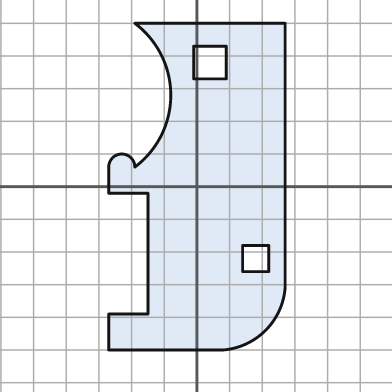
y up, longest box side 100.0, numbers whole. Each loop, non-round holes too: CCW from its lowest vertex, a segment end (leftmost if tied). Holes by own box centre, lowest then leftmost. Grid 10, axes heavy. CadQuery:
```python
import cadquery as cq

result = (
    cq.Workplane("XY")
    .moveTo(-27.0, -50.0)
    .lineTo(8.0, -50.0)
    .threePointArc((21.0, -44.0), (27.0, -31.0))
    .lineTo(27.0, 50.0)
    .lineTo(-19.0, 50.0)
    .threePointArc((-8.0, 28.0), (-19.0, 6.0))
    .threePointArc((-23.0, 10.0), (-27.0, 6.0))
    .lineTo(-27.0, -2.0)
    .lineTo(-15.0, -2.0)
    .lineTo(-15.0, -39.0)
    .lineTo(-27.0, -39.0)
    .close()
    .moveTo(14.0, -26.0)
    .lineTo(22.0, -26.0)
    .lineTo(22.0, -18.0)
    .lineTo(14.0, -18.0)
    .close()
    .moveTo(-1.0, 33.0)
    .lineTo(9.0, 33.0)
    .lineTo(9.0, 43.0)
    .lineTo(-1.0, 43.0)
    .close()
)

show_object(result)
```